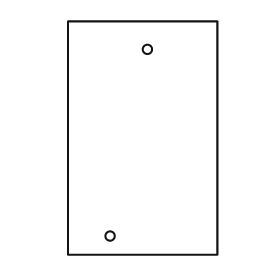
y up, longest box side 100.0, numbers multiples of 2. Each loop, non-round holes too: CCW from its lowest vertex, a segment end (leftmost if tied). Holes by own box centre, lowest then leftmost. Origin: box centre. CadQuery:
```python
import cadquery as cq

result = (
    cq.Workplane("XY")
    .moveTo(-32.0, -50.0)
    .lineTo(32.0, -50.0)
    .lineTo(32.0, 50.0)
    .lineTo(-32.0, 50.0)
    .close()
    .moveTo(-14.0, -42.0)
    .circle(2.0)
    .moveTo(2.0, 38.0)
    .circle(2.0)
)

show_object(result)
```